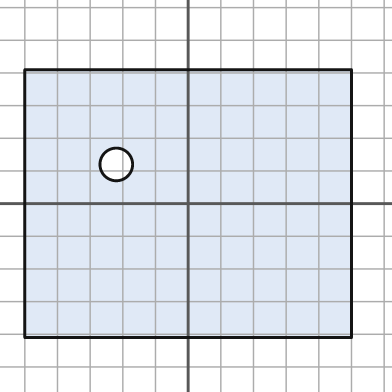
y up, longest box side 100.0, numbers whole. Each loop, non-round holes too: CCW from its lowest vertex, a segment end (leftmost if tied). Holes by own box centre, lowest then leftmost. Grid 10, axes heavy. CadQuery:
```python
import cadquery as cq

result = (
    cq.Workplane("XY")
    .moveTo(-50.0, -41.0)
    .lineTo(50.0, -41.0)
    .lineTo(50.0, 41.0)
    .lineTo(-50.0, 41.0)
    .close()
    .moveTo(-22.0, 12.0)
    .circle(5.0)
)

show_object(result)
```